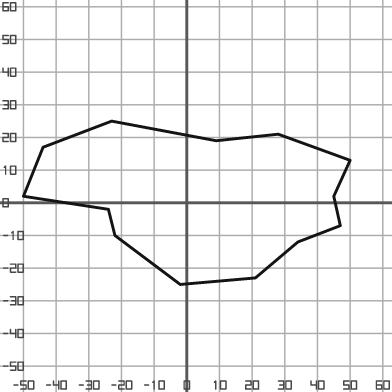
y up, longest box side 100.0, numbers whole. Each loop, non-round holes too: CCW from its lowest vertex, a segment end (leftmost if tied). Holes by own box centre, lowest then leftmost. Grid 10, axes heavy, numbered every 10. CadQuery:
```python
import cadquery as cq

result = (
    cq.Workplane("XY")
    .moveTo(-2.0, -25.0)
    .lineTo(21.0, -23.0)
    .lineTo(34.0, -12.0)
    .lineTo(47.0, -7.0)
    .lineTo(45.0, 2.0)
    .lineTo(50.0, 13.0)
    .lineTo(28.0, 21.0)
    .lineTo(9.0, 19.0)
    .lineTo(-23.0, 25.0)
    .lineTo(-44.0, 17.0)
    .lineTo(-50.0, 2.0)
    .lineTo(-24.0, -2.0)
    .lineTo(-22.0, -10.0)
    .close()
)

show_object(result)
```